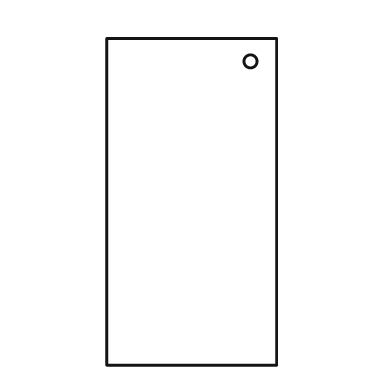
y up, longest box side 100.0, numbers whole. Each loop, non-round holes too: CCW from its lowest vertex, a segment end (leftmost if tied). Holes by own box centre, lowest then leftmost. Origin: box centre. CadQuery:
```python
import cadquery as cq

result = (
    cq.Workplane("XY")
    .moveTo(-26.0, -50.0)
    .lineTo(26.0, -50.0)
    .lineTo(26.0, 50.0)
    .lineTo(-26.0, 50.0)
    .close()
    .moveTo(18.0, 43.0)
    .circle(2.0)
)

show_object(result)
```